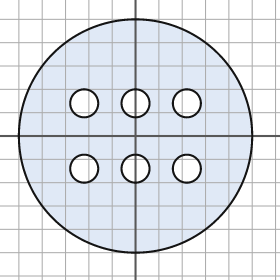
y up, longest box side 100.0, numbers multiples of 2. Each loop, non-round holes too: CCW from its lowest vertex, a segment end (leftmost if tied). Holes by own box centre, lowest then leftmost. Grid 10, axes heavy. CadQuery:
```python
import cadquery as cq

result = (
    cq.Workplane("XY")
    .moveTo(0.0, 0.0)
    .circle(50.0)
    .moveTo(-22.0, -14.0)
    .circle(6.0)
    .moveTo(0.0, -14.0)
    .circle(6.0)
    .moveTo(22.0, -14.0)
    .circle(6.0)
    .moveTo(-22.0, 14.0)
    .circle(6.0)
    .moveTo(0.0, 14.0)
    .circle(6.0)
    .moveTo(22.0, 14.0)
    .circle(6.0)
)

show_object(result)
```